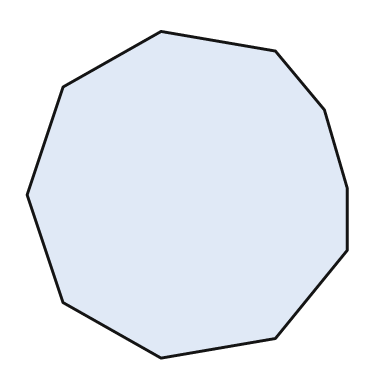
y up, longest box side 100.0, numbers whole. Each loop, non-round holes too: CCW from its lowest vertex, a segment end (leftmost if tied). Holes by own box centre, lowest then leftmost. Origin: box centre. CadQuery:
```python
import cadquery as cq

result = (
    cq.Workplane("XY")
    .moveTo(-8.0, -50.0)
    .lineTo(27.0, -44.0)
    .lineTo(49.0, -17.0)
    .lineTo(49.0, 2.0)
    .lineTo(42.0, 26.0)
    .lineTo(27.0, 44.0)
    .lineTo(-8.0, 50.0)
    .lineTo(-38.0, 33.0)
    .lineTo(-49.0, 0.0)
    .lineTo(-38.0, -33.0)
    .close()
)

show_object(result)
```